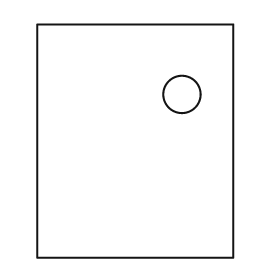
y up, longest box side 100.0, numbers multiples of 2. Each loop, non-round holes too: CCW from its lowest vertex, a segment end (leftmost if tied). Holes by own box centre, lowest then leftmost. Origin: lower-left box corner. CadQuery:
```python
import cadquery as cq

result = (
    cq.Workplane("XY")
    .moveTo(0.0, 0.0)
    .lineTo(84.0, 0.0)
    .lineTo(84.0, 100.0)
    .lineTo(0.0, 100.0)
    .close()
    .moveTo(62.0, 70.0)
    .circle(8.0)
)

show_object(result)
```